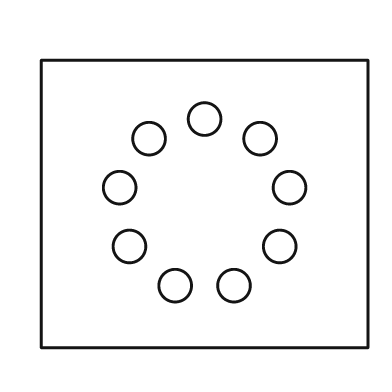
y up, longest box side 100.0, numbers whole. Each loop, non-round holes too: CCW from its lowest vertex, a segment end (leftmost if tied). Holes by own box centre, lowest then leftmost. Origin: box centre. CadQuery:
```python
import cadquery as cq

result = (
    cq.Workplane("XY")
    .moveTo(-50.0, -44.0)
    .lineTo(50.0, -44.0)
    .lineTo(50.0, 44.0)
    .lineTo(-50.0, 44.0)
    .close()
    .moveTo(-9.0, -25.0)
    .circle(5.0)
    .moveTo(9.0, -25.0)
    .circle(5.0)
    .moveTo(-23.0, -13.0)
    .circle(5.0)
    .moveTo(23.0, -13.0)
    .circle(5.0)
    .moveTo(-26.0, 5.0)
    .circle(5.0)
    .moveTo(26.0, 5.0)
    .circle(5.0)
    .moveTo(-17.0, 20.0)
    .circle(5.0)
    .moveTo(17.0, 20.0)
    .circle(5.0)
    .moveTo(0.0, 26.0)
    .circle(5.0)
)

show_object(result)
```